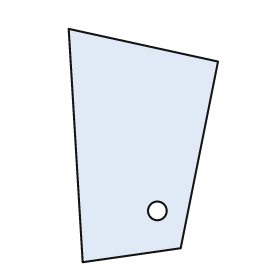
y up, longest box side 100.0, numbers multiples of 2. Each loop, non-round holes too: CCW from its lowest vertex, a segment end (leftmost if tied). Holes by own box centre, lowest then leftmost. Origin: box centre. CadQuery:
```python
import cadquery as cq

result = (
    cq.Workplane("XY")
    .moveTo(-26.0, -50.0)
    .lineTo(16.0, -44.0)
    .lineTo(32.0, 36.0)
    .lineTo(-32.0, 50.0)
    .close()
    .moveTo(6.0, -28.0)
    .circle(4.0)
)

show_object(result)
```